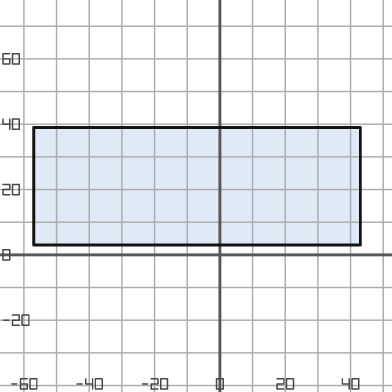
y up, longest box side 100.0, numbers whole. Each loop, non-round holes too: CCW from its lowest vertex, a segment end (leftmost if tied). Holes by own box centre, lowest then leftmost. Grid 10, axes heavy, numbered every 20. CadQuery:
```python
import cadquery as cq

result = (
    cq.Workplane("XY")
    .moveTo(-57.0, 3.0)
    .lineTo(43.0, 3.0)
    .lineTo(43.0, 39.0)
    .lineTo(-57.0, 39.0)
    .close()
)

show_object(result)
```